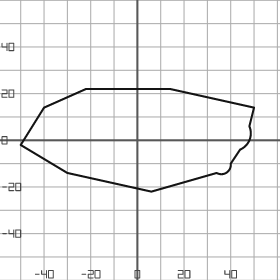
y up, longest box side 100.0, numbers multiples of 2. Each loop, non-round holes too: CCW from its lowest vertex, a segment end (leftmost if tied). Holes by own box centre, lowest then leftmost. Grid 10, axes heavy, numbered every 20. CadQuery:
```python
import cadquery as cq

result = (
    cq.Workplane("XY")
    .moveTo(6.0, -22.0)
    .lineTo(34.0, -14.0)
    .threePointArc((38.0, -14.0), (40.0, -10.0))
    .lineTo(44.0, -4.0)
    .threePointArc((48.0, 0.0), (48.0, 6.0))
    .lineTo(50.0, 14.0)
    .lineTo(14.0, 22.0)
    .lineTo(-22.0, 22.0)
    .lineTo(-40.0, 14.0)
    .lineTo(-50.0, -2.0)
    .lineTo(-30.0, -14.0)
    .close()
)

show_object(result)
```